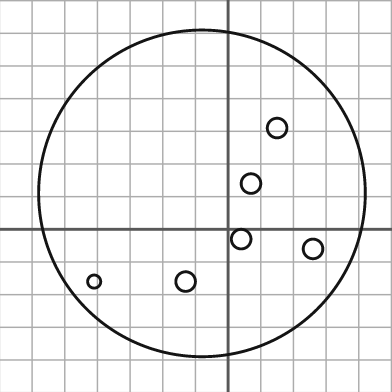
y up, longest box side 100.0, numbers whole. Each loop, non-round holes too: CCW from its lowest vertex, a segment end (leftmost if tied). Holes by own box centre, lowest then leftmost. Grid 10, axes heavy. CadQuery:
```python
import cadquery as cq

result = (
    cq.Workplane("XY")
    .moveTo(-8.0, 11.0)
    .circle(50.0)
    .moveTo(-41.0, -16.0)
    .circle(2.0)
    .moveTo(-13.0, -16.0)
    .circle(3.0)
    .moveTo(26.0, -6.0)
    .circle(3.0)
    .moveTo(4.0, -3.0)
    .circle(3.0)
    .moveTo(7.0, 14.0)
    .circle(3.0)
    .moveTo(15.0, 31.0)
    .circle(3.0)
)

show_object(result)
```